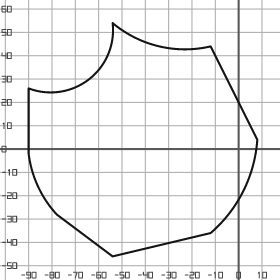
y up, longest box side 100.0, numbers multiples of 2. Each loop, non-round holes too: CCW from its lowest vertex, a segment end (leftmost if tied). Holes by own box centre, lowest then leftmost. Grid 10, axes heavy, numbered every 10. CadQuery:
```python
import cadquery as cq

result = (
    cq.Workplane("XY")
    .moveTo(-54.0, -46.0)
    .lineTo(-12.0, -36.0)
    .threePointArc((2.0, -18.0), (8.0, 4.0))
    .lineTo(-12.0, 44.0)
    .threePointArc((-34.0, 44.0), (-54.0, 54.0))
    .threePointArc((-64.0, 30.0), (-90.0, 26.0))
    .lineTo(-90.0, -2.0)
    .threePointArc((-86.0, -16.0), (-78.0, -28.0))
    .close()
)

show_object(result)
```